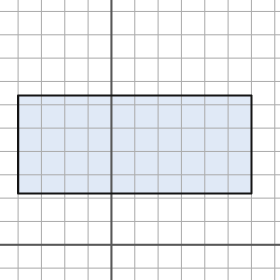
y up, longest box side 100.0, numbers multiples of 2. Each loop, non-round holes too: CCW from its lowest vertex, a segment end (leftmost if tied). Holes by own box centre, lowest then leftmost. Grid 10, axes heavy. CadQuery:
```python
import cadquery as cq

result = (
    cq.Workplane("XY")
    .moveTo(-40.0, 22.0)
    .lineTo(60.0, 22.0)
    .lineTo(60.0, 64.0)
    .lineTo(-40.0, 64.0)
    .close()
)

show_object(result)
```